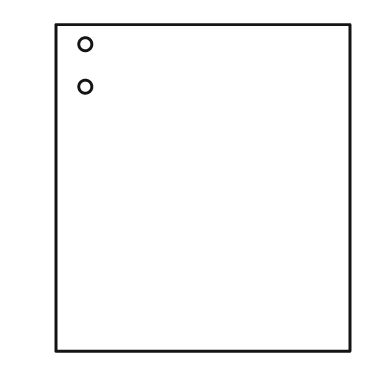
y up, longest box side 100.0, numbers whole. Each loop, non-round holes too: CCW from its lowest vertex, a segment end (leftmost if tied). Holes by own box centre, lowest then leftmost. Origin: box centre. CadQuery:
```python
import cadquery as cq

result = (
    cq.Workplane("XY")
    .moveTo(-45.0, -50.0)
    .lineTo(45.0, -50.0)
    .lineTo(45.0, 50.0)
    .lineTo(-45.0, 50.0)
    .close()
    .moveTo(-36.0, 31.0)
    .circle(2.0)
    .moveTo(-36.0, 44.0)
    .circle(2.0)
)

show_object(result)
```